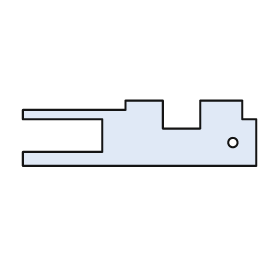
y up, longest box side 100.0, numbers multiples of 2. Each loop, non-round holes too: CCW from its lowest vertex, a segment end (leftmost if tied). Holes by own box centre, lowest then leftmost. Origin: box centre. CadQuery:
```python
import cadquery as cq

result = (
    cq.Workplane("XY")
    .moveTo(-50.0, -14.0)
    .lineTo(50.0, -14.0)
    .lineTo(50.0, 6.0)
    .lineTo(44.0, 6.0)
    .lineTo(44.0, 14.0)
    .lineTo(26.0, 14.0)
    .lineTo(26.0, 2.0)
    .lineTo(10.0, 2.0)
    .lineTo(10.0, 14.0)
    .lineTo(-6.0, 14.0)
    .lineTo(-6.0, 10.0)
    .lineTo(-50.0, 10.0)
    .lineTo(-50.0, 6.0)
    .lineTo(-16.0, 6.0)
    .lineTo(-16.0, -8.0)
    .lineTo(-50.0, -8.0)
    .close()
    .moveTo(40.0, -4.0)
    .circle(2.0)
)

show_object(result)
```